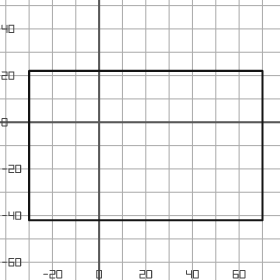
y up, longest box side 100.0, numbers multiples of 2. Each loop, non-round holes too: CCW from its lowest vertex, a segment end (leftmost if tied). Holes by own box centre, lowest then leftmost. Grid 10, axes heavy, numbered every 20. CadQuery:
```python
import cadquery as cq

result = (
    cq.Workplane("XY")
    .moveTo(-30.0, -42.0)
    .lineTo(70.0, -42.0)
    .lineTo(70.0, 22.0)
    .lineTo(-30.0, 22.0)
    .close()
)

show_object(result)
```